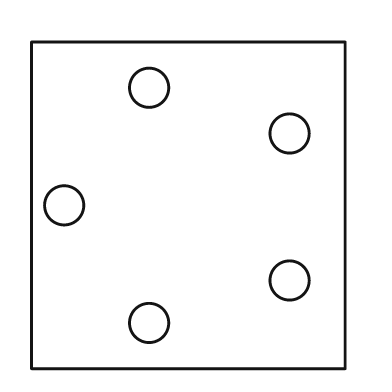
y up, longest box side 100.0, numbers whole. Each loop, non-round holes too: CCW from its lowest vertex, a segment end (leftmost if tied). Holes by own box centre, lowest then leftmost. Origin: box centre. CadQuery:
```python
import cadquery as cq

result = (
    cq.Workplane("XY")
    .moveTo(-48.0, -50.0)
    .lineTo(48.0, -50.0)
    .lineTo(48.0, 50.0)
    .lineTo(-48.0, 50.0)
    .close()
    .moveTo(-12.0, -36.0)
    .circle(6.0)
    .moveTo(31.0, -23.0)
    .circle(6.0)
    .moveTo(-38.0, 0.0)
    .circle(6.0)
    .moveTo(31.0, 22.0)
    .circle(6.0)
    .moveTo(-12.0, 36.0)
    .circle(6.0)
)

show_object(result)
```